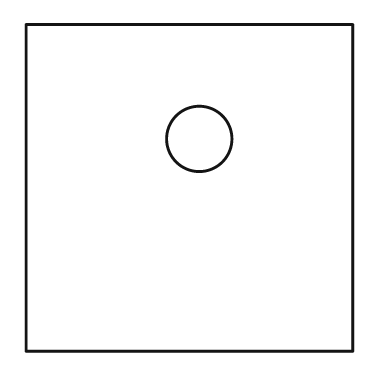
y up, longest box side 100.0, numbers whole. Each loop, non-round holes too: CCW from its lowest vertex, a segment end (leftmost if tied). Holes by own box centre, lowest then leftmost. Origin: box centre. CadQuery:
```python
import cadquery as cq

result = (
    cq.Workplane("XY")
    .moveTo(-50.0, -50.0)
    .lineTo(50.0, -50.0)
    .lineTo(50.0, 50.0)
    .lineTo(-50.0, 50.0)
    .close()
    .moveTo(3.0, 15.0)
    .circle(10.0)
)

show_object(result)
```